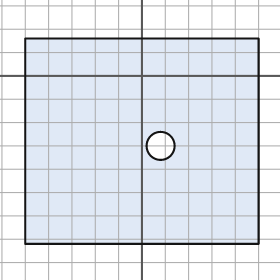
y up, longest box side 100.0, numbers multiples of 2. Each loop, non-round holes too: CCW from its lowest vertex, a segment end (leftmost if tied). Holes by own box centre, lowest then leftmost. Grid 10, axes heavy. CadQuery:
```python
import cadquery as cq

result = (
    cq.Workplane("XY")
    .moveTo(-50.0, -72.0)
    .lineTo(50.0, -72.0)
    .lineTo(50.0, 16.0)
    .lineTo(-50.0, 16.0)
    .close()
    .moveTo(8.0, -30.0)
    .circle(6.0)
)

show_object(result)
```